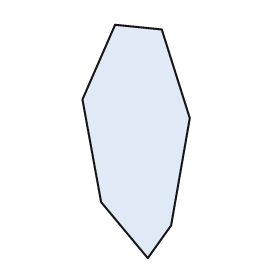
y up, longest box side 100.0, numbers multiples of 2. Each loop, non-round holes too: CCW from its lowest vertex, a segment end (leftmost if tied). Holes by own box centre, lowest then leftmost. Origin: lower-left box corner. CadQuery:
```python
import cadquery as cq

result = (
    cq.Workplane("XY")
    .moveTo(28.0, 0.0)
    .lineTo(38.0, 14.0)
    .lineTo(46.0, 60.0)
    .lineTo(34.0, 98.0)
    .lineTo(14.0, 100.0)
    .lineTo(0.0, 68.0)
    .lineTo(8.0, 24.0)
    .close()
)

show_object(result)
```